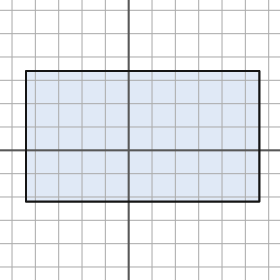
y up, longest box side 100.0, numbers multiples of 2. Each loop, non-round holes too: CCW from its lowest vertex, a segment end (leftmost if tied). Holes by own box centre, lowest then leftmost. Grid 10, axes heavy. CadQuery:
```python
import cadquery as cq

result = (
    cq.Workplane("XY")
    .moveTo(-44.0, -22.0)
    .lineTo(56.0, -22.0)
    .lineTo(56.0, 34.0)
    .lineTo(-44.0, 34.0)
    .close()
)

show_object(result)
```